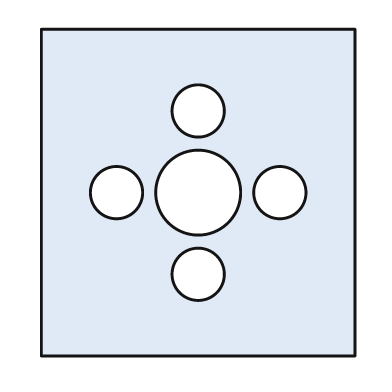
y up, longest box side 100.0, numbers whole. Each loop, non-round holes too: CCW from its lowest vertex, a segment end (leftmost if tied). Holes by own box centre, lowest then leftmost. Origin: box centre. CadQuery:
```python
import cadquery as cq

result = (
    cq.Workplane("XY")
    .moveTo(-48.0, -50.0)
    .lineTo(48.0, -50.0)
    .lineTo(48.0, 50.0)
    .lineTo(-48.0, 50.0)
    .close()
    .moveTo(0.0, -25.0)
    .circle(8.0)
    .moveTo(-25.0, 0.0)
    .circle(8.0)
    .moveTo(0.0, 0.0)
    .circle(13.0)
    .moveTo(25.0, 0.0)
    .circle(8.0)
    .moveTo(0.0, 25.0)
    .circle(8.0)
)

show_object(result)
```